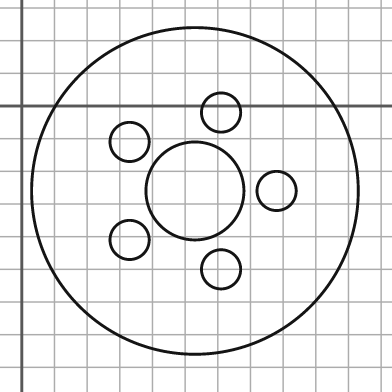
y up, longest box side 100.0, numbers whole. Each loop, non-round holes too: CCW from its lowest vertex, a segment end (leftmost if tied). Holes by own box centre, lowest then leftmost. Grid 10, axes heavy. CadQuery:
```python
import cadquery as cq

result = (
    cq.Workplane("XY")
    .moveTo(53.0, -26.0)
    .circle(50.0)
    .moveTo(61.0, -50.0)
    .circle(6.0)
    .moveTo(33.0, -41.0)
    .circle(6.0)
    .moveTo(53.0, -26.0)
    .circle(15.0)
    .moveTo(78.0, -26.0)
    .circle(6.0)
    .moveTo(33.0, -11.0)
    .circle(6.0)
    .moveTo(61.0, -2.0)
    .circle(6.0)
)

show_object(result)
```